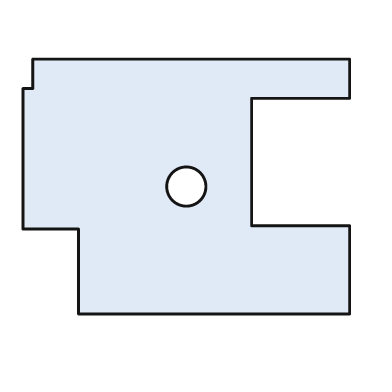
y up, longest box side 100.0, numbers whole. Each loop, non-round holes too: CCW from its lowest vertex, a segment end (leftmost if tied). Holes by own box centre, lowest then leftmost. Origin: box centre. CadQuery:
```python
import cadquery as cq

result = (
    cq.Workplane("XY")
    .moveTo(-33.0, -39.0)
    .lineTo(50.0, -39.0)
    .lineTo(50.0, -12.0)
    .lineTo(20.0, -12.0)
    .lineTo(20.0, 27.0)
    .lineTo(50.0, 27.0)
    .lineTo(50.0, 39.0)
    .lineTo(-47.0, 39.0)
    .lineTo(-47.0, 30.0)
    .lineTo(-50.0, 30.0)
    .lineTo(-50.0, -13.0)
    .lineTo(-33.0, -13.0)
    .close()
    .moveTo(0.0, 0.0)
    .circle(6.0)
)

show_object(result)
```